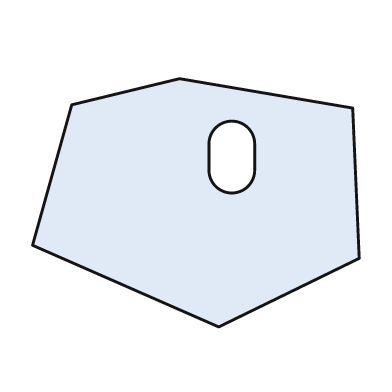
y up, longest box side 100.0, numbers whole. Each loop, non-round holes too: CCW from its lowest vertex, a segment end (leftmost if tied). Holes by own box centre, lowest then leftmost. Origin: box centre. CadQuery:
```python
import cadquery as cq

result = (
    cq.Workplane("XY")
    .moveTo(7.0, -38.0)
    .lineTo(50.0, -17.0)
    .lineTo(48.0, 29.0)
    .lineTo(-5.0, 38.0)
    .lineTo(-38.0, 30.0)
    .lineTo(-50.0, -13.0)
    .close()
    .moveTo(4.0, 10.0)
    .threePointArc((11.0, 3.0), (18.0, 10.0))
    .lineTo(18.0, 18.0)
    .threePointArc((11.0, 25.0), (4.0, 18.0))
    .close()
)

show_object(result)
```